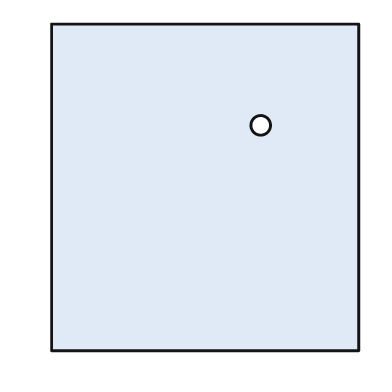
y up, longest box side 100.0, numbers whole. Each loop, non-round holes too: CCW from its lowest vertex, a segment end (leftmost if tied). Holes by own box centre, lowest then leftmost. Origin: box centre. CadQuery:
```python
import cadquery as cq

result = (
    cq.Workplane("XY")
    .moveTo(-47.0, -50.0)
    .lineTo(47.0, -50.0)
    .lineTo(47.0, 50.0)
    .lineTo(-47.0, 50.0)
    .close()
    .moveTo(17.0, 19.0)
    .circle(3.0)
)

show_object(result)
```